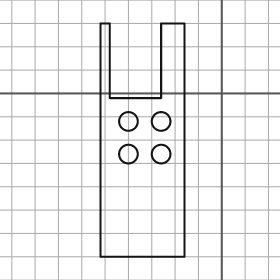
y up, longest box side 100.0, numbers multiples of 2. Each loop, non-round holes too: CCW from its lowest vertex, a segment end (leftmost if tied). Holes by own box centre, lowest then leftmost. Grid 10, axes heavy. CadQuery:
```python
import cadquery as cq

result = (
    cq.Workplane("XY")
    .moveTo(-52.0, -70.0)
    .lineTo(-16.0, -70.0)
    .lineTo(-16.0, 30.0)
    .lineTo(-26.0, 30.0)
    .lineTo(-26.0, -2.0)
    .lineTo(-48.0, -2.0)
    .lineTo(-48.0, 30.0)
    .lineTo(-52.0, 30.0)
    .close()
    .moveTo(-40.0, -26.0)
    .circle(4.0)
    .moveTo(-26.0, -26.0)
    .circle(4.0)
    .moveTo(-40.0, -12.0)
    .circle(4.0)
    .moveTo(-26.0, -12.0)
    .circle(4.0)
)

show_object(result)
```